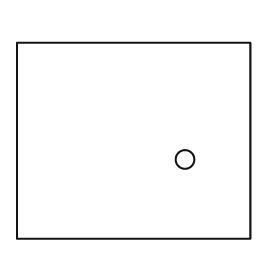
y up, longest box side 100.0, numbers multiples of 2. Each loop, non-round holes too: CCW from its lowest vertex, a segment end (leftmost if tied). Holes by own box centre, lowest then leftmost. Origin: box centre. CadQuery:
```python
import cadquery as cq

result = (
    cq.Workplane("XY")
    .moveTo(-50.0, -42.0)
    .lineTo(50.0, -42.0)
    .lineTo(50.0, 42.0)
    .lineTo(-50.0, 42.0)
    .close()
    .moveTo(22.0, -8.0)
    .circle(4.0)
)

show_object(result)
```